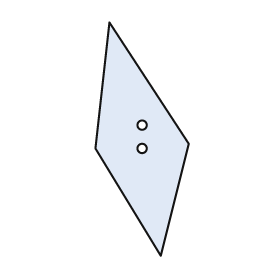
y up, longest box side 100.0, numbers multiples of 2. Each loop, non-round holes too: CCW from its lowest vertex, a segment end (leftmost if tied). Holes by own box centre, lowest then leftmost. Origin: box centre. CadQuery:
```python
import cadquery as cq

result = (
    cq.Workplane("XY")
    .moveTo(8.0, -50.0)
    .lineTo(20.0, -2.0)
    .lineTo(-14.0, 50.0)
    .lineTo(-20.0, -4.0)
    .close()
    .moveTo(0.0, -4.0)
    .circle(2.0)
    .moveTo(0.0, 6.0)
    .circle(2.0)
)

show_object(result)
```